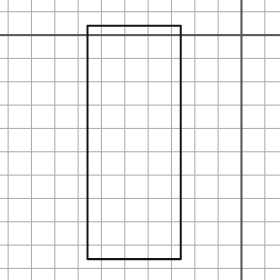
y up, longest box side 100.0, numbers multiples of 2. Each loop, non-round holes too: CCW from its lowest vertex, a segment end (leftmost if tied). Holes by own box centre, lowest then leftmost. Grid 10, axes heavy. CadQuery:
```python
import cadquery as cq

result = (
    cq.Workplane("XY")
    .moveTo(-66.0, -96.0)
    .lineTo(-26.0, -96.0)
    .lineTo(-26.0, 4.0)
    .lineTo(-66.0, 4.0)
    .close()
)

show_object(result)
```